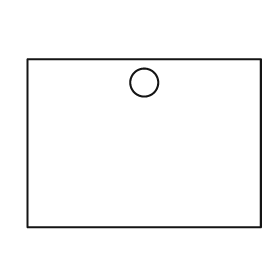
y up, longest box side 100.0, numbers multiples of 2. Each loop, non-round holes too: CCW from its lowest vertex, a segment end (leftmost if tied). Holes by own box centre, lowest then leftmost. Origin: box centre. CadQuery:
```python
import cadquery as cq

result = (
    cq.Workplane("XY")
    .moveTo(-50.0, -36.0)
    .lineTo(50.0, -36.0)
    .lineTo(50.0, 36.0)
    .lineTo(-50.0, 36.0)
    .close()
    .moveTo(0.0, 26.0)
    .circle(6.0)
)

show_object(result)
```